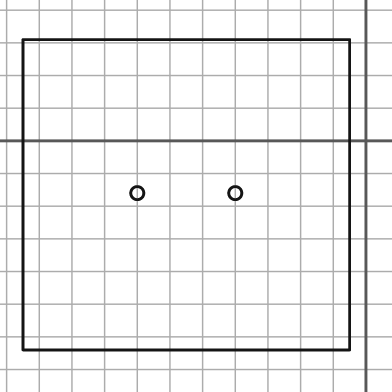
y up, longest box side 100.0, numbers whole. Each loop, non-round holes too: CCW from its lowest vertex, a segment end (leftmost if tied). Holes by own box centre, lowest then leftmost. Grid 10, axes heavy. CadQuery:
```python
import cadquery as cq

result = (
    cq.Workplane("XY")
    .moveTo(-105.0, -64.0)
    .lineTo(-5.0, -64.0)
    .lineTo(-5.0, 31.0)
    .lineTo(-105.0, 31.0)
    .close()
    .moveTo(-70.0, -16.0)
    .circle(2.0)
    .moveTo(-40.0, -16.0)
    .circle(2.0)
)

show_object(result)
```